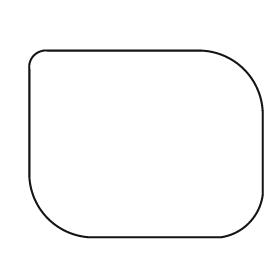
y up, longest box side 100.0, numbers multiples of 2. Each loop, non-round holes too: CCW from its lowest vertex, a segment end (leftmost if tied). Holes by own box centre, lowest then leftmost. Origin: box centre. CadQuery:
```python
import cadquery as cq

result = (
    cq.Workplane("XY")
    .moveTo(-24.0, -40.0)
    .lineTo(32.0, -40.0)
    .threePointArc((44.0, -34.0), (50.0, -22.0))
    .lineTo(50.0, 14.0)
    .threePointArc((42.0, 32.0), (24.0, 40.0))
    .lineTo(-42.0, 40.0)
    .threePointArc((-48.0, 38.0), (-50.0, 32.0))
    .lineTo(-50.0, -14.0)
    .threePointArc((-42.0, -32.0), (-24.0, -40.0))
    .close()
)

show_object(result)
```